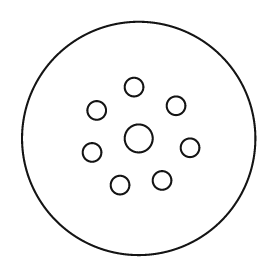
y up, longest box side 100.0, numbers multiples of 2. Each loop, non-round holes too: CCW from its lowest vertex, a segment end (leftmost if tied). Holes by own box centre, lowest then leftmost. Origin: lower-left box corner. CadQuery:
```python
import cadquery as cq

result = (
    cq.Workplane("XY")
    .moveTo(50.0, 50.0)
    .circle(50.0)
    .moveTo(42.0, 30.0)
    .circle(4.0)
    .moveTo(60.0, 32.0)
    .circle(4.0)
    .moveTo(30.0, 44.0)
    .circle(4.0)
    .moveTo(72.0, 46.0)
    .circle(4.0)
    .moveTo(50.0, 50.0)
    .circle(6.0)
    .moveTo(32.0, 62.0)
    .circle(4.0)
    .moveTo(66.0, 64.0)
    .circle(4.0)
    .moveTo(48.0, 72.0)
    .circle(4.0)
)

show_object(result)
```